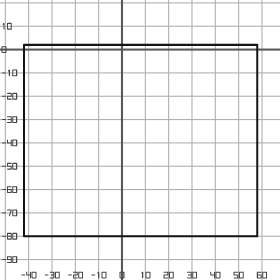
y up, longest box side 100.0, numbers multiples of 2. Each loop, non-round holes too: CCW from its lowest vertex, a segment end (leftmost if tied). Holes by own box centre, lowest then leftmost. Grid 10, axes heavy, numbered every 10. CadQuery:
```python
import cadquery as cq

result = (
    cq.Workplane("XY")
    .moveTo(-42.0, -80.0)
    .lineTo(58.0, -80.0)
    .lineTo(58.0, 2.0)
    .lineTo(-42.0, 2.0)
    .close()
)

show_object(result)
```